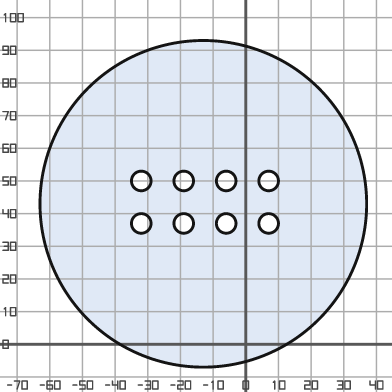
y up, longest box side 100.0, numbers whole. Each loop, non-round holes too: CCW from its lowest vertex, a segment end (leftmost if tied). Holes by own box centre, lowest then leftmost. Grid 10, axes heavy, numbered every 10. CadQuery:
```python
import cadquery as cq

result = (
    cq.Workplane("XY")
    .moveTo(-13.0, 43.0)
    .circle(50.0)
    .moveTo(-32.0, 37.0)
    .circle(3.0)
    .moveTo(-19.0, 37.0)
    .circle(3.0)
    .moveTo(-6.0, 37.0)
    .circle(3.0)
    .moveTo(7.0, 37.0)
    .circle(3.0)
    .moveTo(-32.0, 50.0)
    .circle(3.0)
    .moveTo(-19.0, 50.0)
    .circle(3.0)
    .moveTo(-6.0, 50.0)
    .circle(3.0)
    .moveTo(7.0, 50.0)
    .circle(3.0)
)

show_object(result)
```